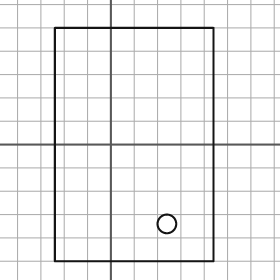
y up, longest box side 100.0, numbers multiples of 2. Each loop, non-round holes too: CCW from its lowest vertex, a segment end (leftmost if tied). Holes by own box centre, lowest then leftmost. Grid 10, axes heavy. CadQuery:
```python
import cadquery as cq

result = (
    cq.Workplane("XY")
    .moveTo(-24.0, -50.0)
    .lineTo(44.0, -50.0)
    .lineTo(44.0, 50.0)
    .lineTo(-24.0, 50.0)
    .close()
    .moveTo(24.0, -34.0)
    .circle(4.0)
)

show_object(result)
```